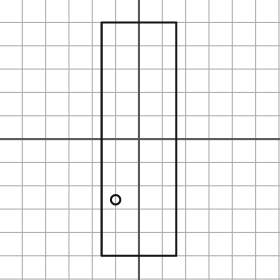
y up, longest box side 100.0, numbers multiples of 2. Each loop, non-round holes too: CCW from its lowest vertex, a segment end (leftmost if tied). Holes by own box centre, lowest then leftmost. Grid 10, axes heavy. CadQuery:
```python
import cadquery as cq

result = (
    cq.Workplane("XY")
    .moveTo(-16.0, -50.0)
    .lineTo(16.0, -50.0)
    .lineTo(16.0, 50.0)
    .lineTo(-16.0, 50.0)
    .close()
    .moveTo(-10.0, -26.0)
    .circle(2.0)
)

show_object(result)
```